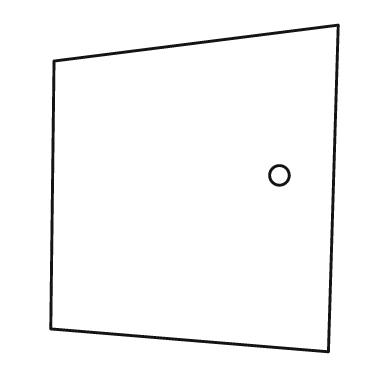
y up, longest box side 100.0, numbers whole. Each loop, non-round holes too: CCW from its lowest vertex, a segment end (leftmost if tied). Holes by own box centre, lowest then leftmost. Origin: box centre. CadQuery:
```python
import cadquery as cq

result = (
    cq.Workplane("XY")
    .moveTo(41.0, -50.0)
    .lineTo(44.0, 50.0)
    .lineTo(-43.0, 39.0)
    .lineTo(-44.0, -43.0)
    .close()
    .moveTo(26.0, 4.0)
    .circle(3.0)
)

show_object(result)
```